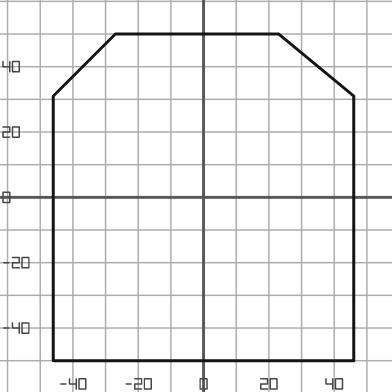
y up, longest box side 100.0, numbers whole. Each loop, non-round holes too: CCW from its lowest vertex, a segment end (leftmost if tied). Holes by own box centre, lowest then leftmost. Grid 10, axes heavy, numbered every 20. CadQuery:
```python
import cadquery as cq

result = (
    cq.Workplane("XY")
    .moveTo(-46.0, -50.0)
    .lineTo(46.0, -50.0)
    .lineTo(46.0, 31.0)
    .lineTo(23.0, 50.0)
    .lineTo(-27.0, 50.0)
    .lineTo(-46.0, 31.0)
    .close()
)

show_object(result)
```